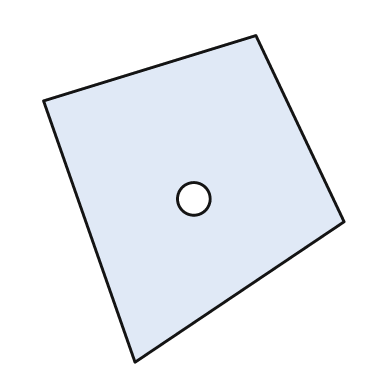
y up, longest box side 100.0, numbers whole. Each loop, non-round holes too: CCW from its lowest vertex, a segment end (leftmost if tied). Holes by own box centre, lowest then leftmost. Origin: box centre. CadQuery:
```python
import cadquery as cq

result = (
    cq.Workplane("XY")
    .moveTo(-18.0, -50.0)
    .lineTo(46.0, -7.0)
    .lineTo(19.0, 50.0)
    .lineTo(-46.0, 30.0)
    .close()
    .moveTo(0.0, 0.0)
    .circle(5.0)
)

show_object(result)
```